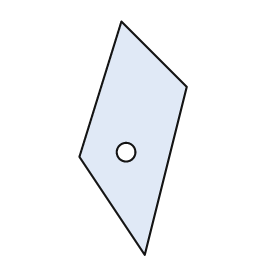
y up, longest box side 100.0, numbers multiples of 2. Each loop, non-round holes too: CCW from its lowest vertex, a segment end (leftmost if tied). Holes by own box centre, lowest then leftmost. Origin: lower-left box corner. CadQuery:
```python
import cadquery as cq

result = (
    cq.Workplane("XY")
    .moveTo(28.0, 0.0)
    .lineTo(46.0, 72.0)
    .lineTo(18.0, 100.0)
    .lineTo(0.0, 42.0)
    .close()
    .moveTo(20.0, 44.0)
    .circle(4.0)
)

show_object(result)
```